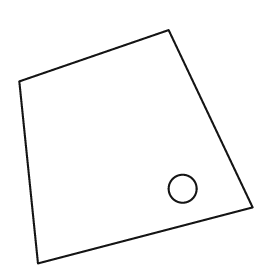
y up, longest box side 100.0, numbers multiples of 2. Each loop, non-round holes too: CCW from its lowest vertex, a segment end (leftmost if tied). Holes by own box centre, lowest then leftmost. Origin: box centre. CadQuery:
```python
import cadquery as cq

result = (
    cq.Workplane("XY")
    .moveTo(-42.0, -50.0)
    .lineTo(50.0, -26.0)
    .lineTo(14.0, 50.0)
    .lineTo(-50.0, 28.0)
    .close()
    .moveTo(20.0, -18.0)
    .circle(6.0)
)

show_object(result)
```